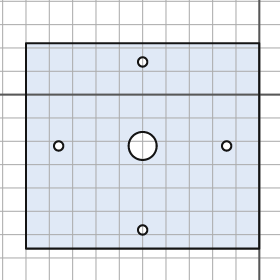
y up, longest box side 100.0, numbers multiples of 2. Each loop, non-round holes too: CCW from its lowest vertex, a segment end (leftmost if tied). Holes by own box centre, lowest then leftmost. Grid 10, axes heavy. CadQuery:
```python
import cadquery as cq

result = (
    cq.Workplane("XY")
    .moveTo(-100.0, -66.0)
    .lineTo(0.0, -66.0)
    .lineTo(0.0, 22.0)
    .lineTo(-100.0, 22.0)
    .close()
    .moveTo(-50.0, -58.0)
    .circle(2.0)
    .moveTo(-86.0, -22.0)
    .circle(2.0)
    .moveTo(-50.0, -22.0)
    .circle(6.0)
    .moveTo(-14.0, -22.0)
    .circle(2.0)
    .moveTo(-50.0, 14.0)
    .circle(2.0)
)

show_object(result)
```